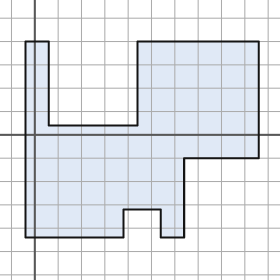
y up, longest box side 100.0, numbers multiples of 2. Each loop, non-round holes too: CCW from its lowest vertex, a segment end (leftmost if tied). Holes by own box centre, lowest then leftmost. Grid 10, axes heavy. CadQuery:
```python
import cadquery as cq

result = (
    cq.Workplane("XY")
    .moveTo(-4.0, -44.0)
    .lineTo(38.0, -44.0)
    .lineTo(38.0, -32.0)
    .lineTo(54.0, -32.0)
    .lineTo(54.0, -44.0)
    .lineTo(64.0, -44.0)
    .lineTo(64.0, -10.0)
    .lineTo(96.0, -10.0)
    .lineTo(96.0, 40.0)
    .lineTo(44.0, 40.0)
    .lineTo(44.0, 4.0)
    .lineTo(6.0, 4.0)
    .lineTo(6.0, 40.0)
    .lineTo(-4.0, 40.0)
    .close()
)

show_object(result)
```